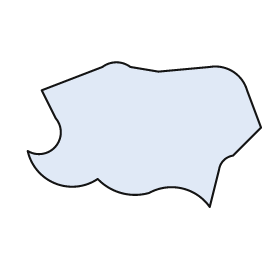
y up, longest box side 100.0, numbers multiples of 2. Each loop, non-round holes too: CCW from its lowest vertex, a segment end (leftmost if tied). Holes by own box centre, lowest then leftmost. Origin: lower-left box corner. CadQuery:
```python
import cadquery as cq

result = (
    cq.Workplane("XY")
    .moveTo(78.0, 0.0)
    .lineTo(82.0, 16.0)
    .threePointArc((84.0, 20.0), (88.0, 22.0))
    .lineTo(100.0, 34.0)
    .lineTo(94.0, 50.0)
    .threePointArc((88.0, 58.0), (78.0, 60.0))
    .lineTo(56.0, 58.0)
    .lineTo(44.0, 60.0)
    .threePointArc((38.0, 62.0), (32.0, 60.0))
    .lineTo(6.0, 50.0)
    .lineTo(12.0, 38.0)
    .threePointArc((12.0, 26.0), (0.0, 24.0))
    .threePointArc((12.0, 10.0), (30.0, 12.0))
    .threePointArc((40.0, 6.0), (52.0, 6.0))
    .threePointArc((66.0, 8.0), (78.0, 0.0))
    .close()
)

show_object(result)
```